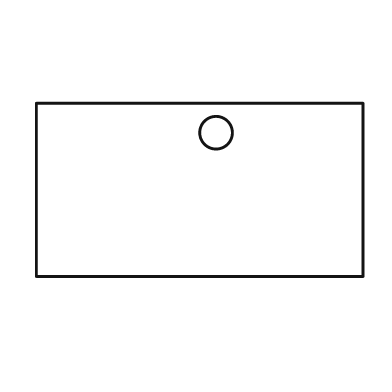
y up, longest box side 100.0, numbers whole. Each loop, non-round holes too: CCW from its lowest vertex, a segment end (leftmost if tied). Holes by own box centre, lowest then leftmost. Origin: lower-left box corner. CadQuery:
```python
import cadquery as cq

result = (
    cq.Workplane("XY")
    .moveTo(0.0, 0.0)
    .lineTo(100.0, 0.0)
    .lineTo(100.0, 53.0)
    .lineTo(0.0, 53.0)
    .close()
    .moveTo(55.0, 44.0)
    .circle(5.0)
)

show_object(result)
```